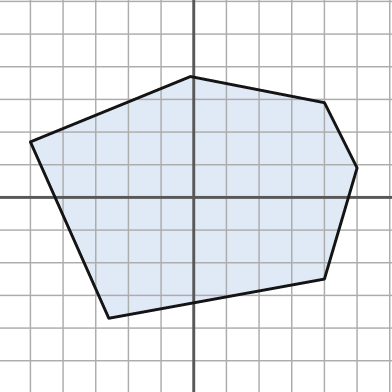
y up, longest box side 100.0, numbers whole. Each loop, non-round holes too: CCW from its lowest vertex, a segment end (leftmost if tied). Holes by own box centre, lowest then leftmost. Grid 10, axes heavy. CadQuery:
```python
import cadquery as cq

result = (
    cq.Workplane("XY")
    .moveTo(-26.0, -37.0)
    .lineTo(40.0, -25.0)
    .lineTo(50.0, 9.0)
    .lineTo(40.0, 29.0)
    .lineTo(-1.0, 37.0)
    .lineTo(-50.0, 17.0)
    .close()
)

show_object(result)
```